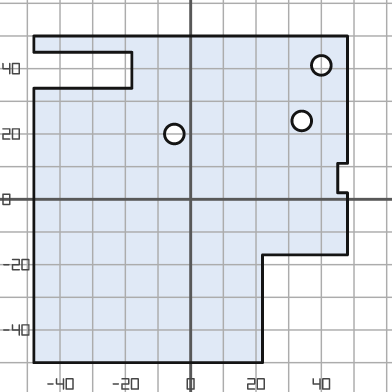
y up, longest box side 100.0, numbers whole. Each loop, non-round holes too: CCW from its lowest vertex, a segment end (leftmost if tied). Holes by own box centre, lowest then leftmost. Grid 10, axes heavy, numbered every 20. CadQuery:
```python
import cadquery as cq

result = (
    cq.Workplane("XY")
    .moveTo(-48.0, -50.0)
    .lineTo(22.0, -50.0)
    .lineTo(22.0, -17.0)
    .lineTo(48.0, -17.0)
    .lineTo(48.0, 2.0)
    .lineTo(45.0, 2.0)
    .lineTo(45.0, 11.0)
    .lineTo(48.0, 11.0)
    .lineTo(48.0, 50.0)
    .lineTo(-48.0, 50.0)
    .lineTo(-48.0, 45.0)
    .lineTo(-18.0, 45.0)
    .lineTo(-18.0, 34.0)
    .lineTo(-48.0, 34.0)
    .close()
    .moveTo(-5.0, 20.0)
    .circle(3.0)
    .moveTo(34.0, 24.0)
    .circle(3.0)
    .moveTo(40.0, 41.0)
    .circle(3.0)
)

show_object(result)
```